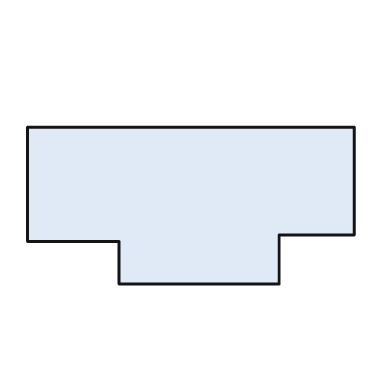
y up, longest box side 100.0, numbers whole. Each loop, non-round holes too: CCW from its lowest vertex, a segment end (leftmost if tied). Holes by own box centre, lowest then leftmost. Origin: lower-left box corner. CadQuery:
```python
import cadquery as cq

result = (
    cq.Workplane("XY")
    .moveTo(28.0, 0.0)
    .lineTo(77.0, 0.0)
    .lineTo(77.0, 15.0)
    .lineTo(100.0, 15.0)
    .lineTo(100.0, 48.0)
    .lineTo(0.0, 48.0)
    .lineTo(0.0, 13.0)
    .lineTo(28.0, 13.0)
    .close()
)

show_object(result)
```